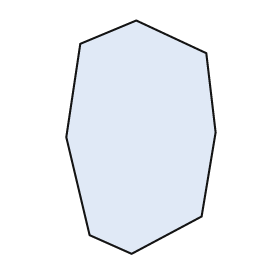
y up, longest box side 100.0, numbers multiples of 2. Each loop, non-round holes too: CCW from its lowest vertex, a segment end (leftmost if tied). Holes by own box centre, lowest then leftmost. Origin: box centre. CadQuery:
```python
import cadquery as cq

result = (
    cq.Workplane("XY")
    .moveTo(-4.0, -50.0)
    .lineTo(26.0, -34.0)
    .lineTo(32.0, 2.0)
    .lineTo(28.0, 36.0)
    .lineTo(-2.0, 50.0)
    .lineTo(-26.0, 40.0)
    .lineTo(-32.0, 0.0)
    .lineTo(-22.0, -42.0)
    .close()
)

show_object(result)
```